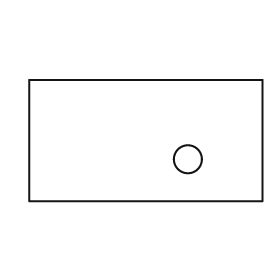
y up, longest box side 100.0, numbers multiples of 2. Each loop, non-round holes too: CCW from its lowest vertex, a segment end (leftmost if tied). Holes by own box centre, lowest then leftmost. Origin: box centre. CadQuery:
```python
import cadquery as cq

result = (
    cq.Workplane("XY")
    .moveTo(-50.0, -26.0)
    .lineTo(50.0, -26.0)
    .lineTo(50.0, 26.0)
    .lineTo(-50.0, 26.0)
    .close()
    .moveTo(18.0, -8.0)
    .circle(6.0)
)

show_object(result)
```